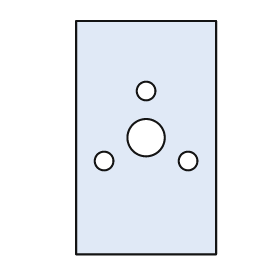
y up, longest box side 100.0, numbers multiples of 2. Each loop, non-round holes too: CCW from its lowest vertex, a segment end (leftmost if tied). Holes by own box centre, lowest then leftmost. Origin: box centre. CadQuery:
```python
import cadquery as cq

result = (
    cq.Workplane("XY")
    .moveTo(-30.0, -50.0)
    .lineTo(30.0, -50.0)
    .lineTo(30.0, 50.0)
    .lineTo(-30.0, 50.0)
    .close()
    .moveTo(-18.0, -10.0)
    .circle(4.0)
    .moveTo(18.0, -10.0)
    .circle(4.0)
    .moveTo(0.0, 0.0)
    .circle(8.0)
    .moveTo(0.0, 20.0)
    .circle(4.0)
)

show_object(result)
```